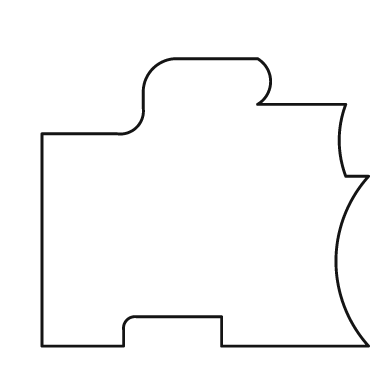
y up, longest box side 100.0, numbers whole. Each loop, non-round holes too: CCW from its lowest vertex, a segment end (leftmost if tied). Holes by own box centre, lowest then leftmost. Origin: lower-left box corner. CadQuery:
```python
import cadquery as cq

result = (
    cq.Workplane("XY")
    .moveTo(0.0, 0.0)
    .lineTo(25.0, 0.0)
    .lineTo(25.0, 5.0)
    .threePointArc((26.0, 8.0), (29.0, 9.0))
    .lineTo(55.0, 9.0)
    .lineTo(55.0, 0.0)
    .lineTo(100.0, 0.0)
    .threePointArc((90.0, 26.0), (100.0, 52.0))
    .lineTo(93.0, 52.0)
    .threePointArc((91.0, 63.0), (93.0, 74.0))
    .lineTo(66.0, 74.0)
    .threePointArc((70.0, 81.0), (66.0, 88.0))
    .lineTo(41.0, 88.0)
    .threePointArc((34.0, 85.0), (31.0, 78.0))
    .lineTo(31.0, 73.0)
    .threePointArc((29.0, 67.0), (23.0, 65.0))
    .lineTo(0.0, 65.0)
    .close()
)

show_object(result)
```